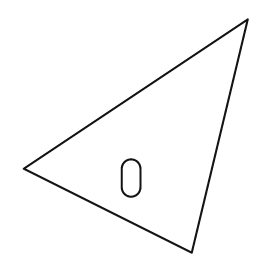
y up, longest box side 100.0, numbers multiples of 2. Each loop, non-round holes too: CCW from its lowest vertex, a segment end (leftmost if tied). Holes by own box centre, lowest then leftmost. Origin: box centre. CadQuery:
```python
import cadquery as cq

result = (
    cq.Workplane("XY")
    .moveTo(24.0, -50.0)
    .lineTo(48.0, 50.0)
    .lineTo(-48.0, -14.0)
    .close()
    .moveTo(-6.0, -22.0)
    .threePointArc((-2.0, -26.0), (2.0, -22.0))
    .lineTo(2.0, -14.0)
    .threePointArc((-2.0, -10.0), (-6.0, -14.0))
    .close()
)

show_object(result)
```